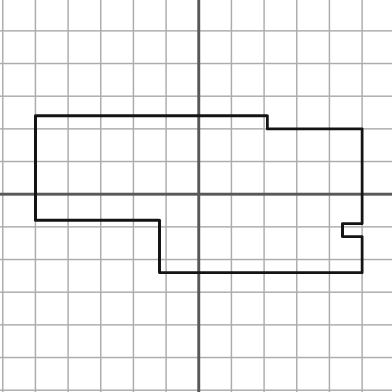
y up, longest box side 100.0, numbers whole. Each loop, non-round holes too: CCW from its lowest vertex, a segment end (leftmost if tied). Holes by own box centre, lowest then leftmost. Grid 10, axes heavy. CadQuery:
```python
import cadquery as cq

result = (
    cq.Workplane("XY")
    .moveTo(-12.0, -24.0)
    .lineTo(50.0, -24.0)
    .lineTo(50.0, -13.0)
    .lineTo(44.0, -13.0)
    .lineTo(44.0, -9.0)
    .lineTo(50.0, -9.0)
    .lineTo(50.0, 20.0)
    .lineTo(21.0, 20.0)
    .lineTo(21.0, 24.0)
    .lineTo(-50.0, 24.0)
    .lineTo(-50.0, -8.0)
    .lineTo(-12.0, -8.0)
    .close()
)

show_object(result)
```